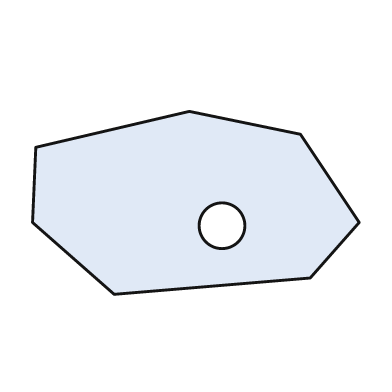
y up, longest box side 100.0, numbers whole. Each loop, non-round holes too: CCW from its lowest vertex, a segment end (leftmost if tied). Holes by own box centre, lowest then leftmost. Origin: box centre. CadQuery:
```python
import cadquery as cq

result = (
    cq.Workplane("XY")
    .moveTo(-25.0, -28.0)
    .lineTo(35.0, -23.0)
    .lineTo(50.0, -6.0)
    .lineTo(32.0, 21.0)
    .lineTo(-2.0, 28.0)
    .lineTo(-49.0, 17.0)
    .lineTo(-50.0, -6.0)
    .close()
    .moveTo(8.0, -7.0)
    .circle(7.0)
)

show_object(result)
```